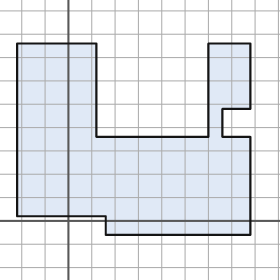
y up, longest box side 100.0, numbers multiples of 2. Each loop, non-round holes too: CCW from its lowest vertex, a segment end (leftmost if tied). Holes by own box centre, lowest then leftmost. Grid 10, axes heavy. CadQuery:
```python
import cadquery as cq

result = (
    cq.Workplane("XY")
    .moveTo(16.0, -6.0)
    .lineTo(78.0, -6.0)
    .lineTo(78.0, 36.0)
    .lineTo(66.0, 36.0)
    .lineTo(66.0, 48.0)
    .lineTo(78.0, 48.0)
    .lineTo(78.0, 76.0)
    .lineTo(60.0, 76.0)
    .lineTo(60.0, 36.0)
    .lineTo(12.0, 36.0)
    .lineTo(12.0, 76.0)
    .lineTo(-22.0, 76.0)
    .lineTo(-22.0, 2.0)
    .lineTo(16.0, 2.0)
    .close()
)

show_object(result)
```